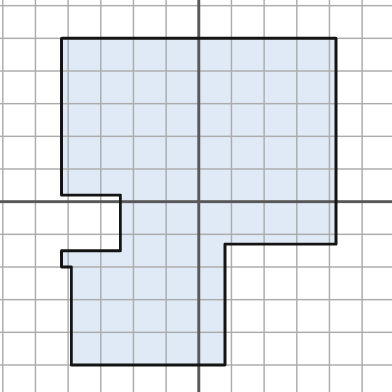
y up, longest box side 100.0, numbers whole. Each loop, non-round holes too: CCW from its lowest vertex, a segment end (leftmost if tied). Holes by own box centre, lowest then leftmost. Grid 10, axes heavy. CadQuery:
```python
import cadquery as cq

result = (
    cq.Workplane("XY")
    .moveTo(-39.0, -50.0)
    .lineTo(8.0, -50.0)
    .lineTo(8.0, -13.0)
    .lineTo(42.0, -13.0)
    .lineTo(42.0, 50.0)
    .lineTo(-42.0, 50.0)
    .lineTo(-42.0, 2.0)
    .lineTo(-24.0, 2.0)
    .lineTo(-24.0, -15.0)
    .lineTo(-42.0, -15.0)
    .lineTo(-42.0, -20.0)
    .lineTo(-39.0, -20.0)
    .close()
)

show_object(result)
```